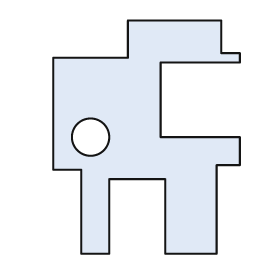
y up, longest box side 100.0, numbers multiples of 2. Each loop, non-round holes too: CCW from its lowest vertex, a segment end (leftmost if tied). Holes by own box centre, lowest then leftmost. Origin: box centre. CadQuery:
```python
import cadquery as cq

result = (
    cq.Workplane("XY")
    .moveTo(-28.0, -50.0)
    .lineTo(-16.0, -50.0)
    .lineTo(-16.0, -18.0)
    .lineTo(8.0, -18.0)
    .lineTo(8.0, -50.0)
    .lineTo(30.0, -50.0)
    .lineTo(30.0, -12.0)
    .lineTo(40.0, -12.0)
    .lineTo(40.0, 0.0)
    .lineTo(6.0, 0.0)
    .lineTo(6.0, 32.0)
    .lineTo(40.0, 32.0)
    .lineTo(40.0, 36.0)
    .lineTo(32.0, 36.0)
    .lineTo(32.0, 50.0)
    .lineTo(-8.0, 50.0)
    .lineTo(-8.0, 34.0)
    .lineTo(-40.0, 34.0)
    .lineTo(-40.0, -14.0)
    .lineTo(-28.0, -14.0)
    .close()
    .moveTo(-24.0, 0.0)
    .circle(8.0)
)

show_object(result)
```